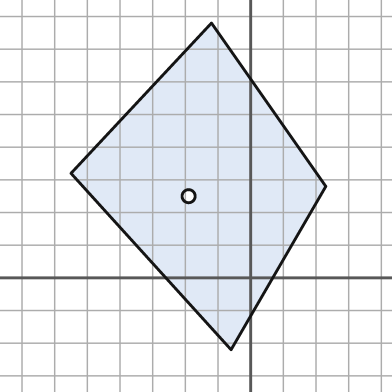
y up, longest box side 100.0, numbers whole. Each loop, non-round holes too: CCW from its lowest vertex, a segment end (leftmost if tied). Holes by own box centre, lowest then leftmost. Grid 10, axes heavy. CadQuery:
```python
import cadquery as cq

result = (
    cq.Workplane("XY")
    .moveTo(-6.0, -22.0)
    .lineTo(23.0, 28.0)
    .lineTo(-12.0, 78.0)
    .lineTo(-55.0, 32.0)
    .close()
    .moveTo(-19.0, 25.0)
    .circle(2.0)
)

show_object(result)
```